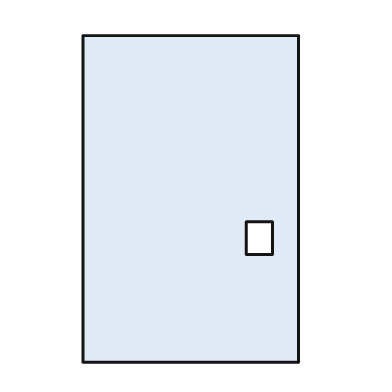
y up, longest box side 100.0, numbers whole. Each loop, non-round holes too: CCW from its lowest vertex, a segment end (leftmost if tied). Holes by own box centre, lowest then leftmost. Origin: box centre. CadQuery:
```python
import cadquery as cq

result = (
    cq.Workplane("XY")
    .moveTo(-33.0, -50.0)
    .lineTo(33.0, -50.0)
    .lineTo(33.0, 50.0)
    .lineTo(-33.0, 50.0)
    .close()
    .moveTo(17.0, -17.0)
    .lineTo(25.0, -17.0)
    .lineTo(25.0, -7.0)
    .lineTo(17.0, -7.0)
    .close()
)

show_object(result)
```